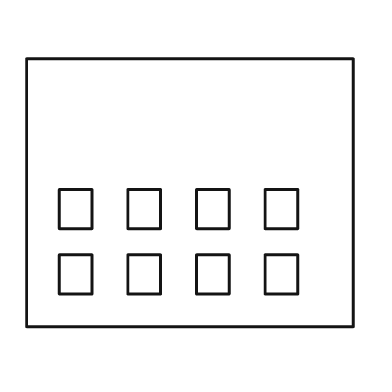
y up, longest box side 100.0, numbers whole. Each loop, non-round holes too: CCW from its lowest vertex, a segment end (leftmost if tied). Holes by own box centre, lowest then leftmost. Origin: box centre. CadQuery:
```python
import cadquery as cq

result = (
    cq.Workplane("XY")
    .moveTo(-50.0, -41.0)
    .lineTo(50.0, -41.0)
    .lineTo(50.0, 41.0)
    .lineTo(-50.0, 41.0)
    .close()
    .moveTo(-40.0, -31.0)
    .lineTo(-30.0, -31.0)
    .lineTo(-30.0, -19.0)
    .lineTo(-40.0, -19.0)
    .close()
    .moveTo(-19.0, -31.0)
    .lineTo(-9.0, -31.0)
    .lineTo(-9.0, -19.0)
    .lineTo(-19.0, -19.0)
    .close()
    .moveTo(2.0, -31.0)
    .lineTo(12.0, -31.0)
    .lineTo(12.0, -19.0)
    .lineTo(2.0, -19.0)
    .close()
    .moveTo(23.0, -31.0)
    .lineTo(33.0, -31.0)
    .lineTo(33.0, -19.0)
    .lineTo(23.0, -19.0)
    .close()
    .moveTo(-40.0, -11.0)
    .lineTo(-30.0, -11.0)
    .lineTo(-30.0, 1.0)
    .lineTo(-40.0, 1.0)
    .close()
    .moveTo(-19.0, -11.0)
    .lineTo(-9.0, -11.0)
    .lineTo(-9.0, 1.0)
    .lineTo(-19.0, 1.0)
    .close()
    .moveTo(2.0, -11.0)
    .lineTo(12.0, -11.0)
    .lineTo(12.0, 1.0)
    .lineTo(2.0, 1.0)
    .close()
    .moveTo(23.0, -11.0)
    .lineTo(33.0, -11.0)
    .lineTo(33.0, 1.0)
    .lineTo(23.0, 1.0)
    .close()
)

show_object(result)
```